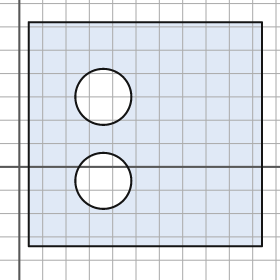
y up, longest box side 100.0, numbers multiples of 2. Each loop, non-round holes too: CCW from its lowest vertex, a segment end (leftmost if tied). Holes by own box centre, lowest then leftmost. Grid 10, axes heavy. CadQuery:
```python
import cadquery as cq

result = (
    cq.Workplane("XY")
    .moveTo(4.0, -34.0)
    .lineTo(104.0, -34.0)
    .lineTo(104.0, 62.0)
    .lineTo(4.0, 62.0)
    .close()
    .moveTo(36.0, -6.0)
    .circle(12.0)
    .moveTo(36.0, 30.0)
    .circle(12.0)
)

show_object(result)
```